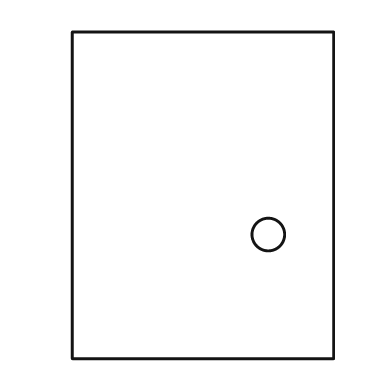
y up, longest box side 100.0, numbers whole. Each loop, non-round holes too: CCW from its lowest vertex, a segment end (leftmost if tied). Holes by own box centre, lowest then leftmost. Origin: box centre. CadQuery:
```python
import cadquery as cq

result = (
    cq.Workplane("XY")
    .moveTo(-40.0, -50.0)
    .lineTo(40.0, -50.0)
    .lineTo(40.0, 50.0)
    .lineTo(-40.0, 50.0)
    .close()
    .moveTo(20.0, -12.0)
    .circle(5.0)
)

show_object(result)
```